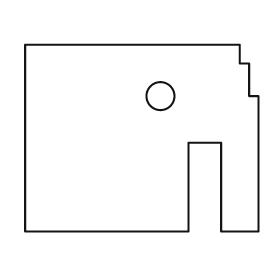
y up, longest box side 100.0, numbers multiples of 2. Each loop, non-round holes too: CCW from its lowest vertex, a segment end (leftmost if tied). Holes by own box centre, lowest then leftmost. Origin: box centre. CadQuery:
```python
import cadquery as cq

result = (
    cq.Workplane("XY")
    .moveTo(-50.0, -40.0)
    .lineTo(20.0, -40.0)
    .lineTo(20.0, -2.0)
    .lineTo(34.0, -2.0)
    .lineTo(34.0, -40.0)
    .lineTo(50.0, -40.0)
    .lineTo(50.0, 18.0)
    .lineTo(46.0, 18.0)
    .lineTo(46.0, 32.0)
    .lineTo(42.0, 32.0)
    .lineTo(42.0, 40.0)
    .lineTo(-50.0, 40.0)
    .close()
    .moveTo(8.0, 18.0)
    .circle(6.0)
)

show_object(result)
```